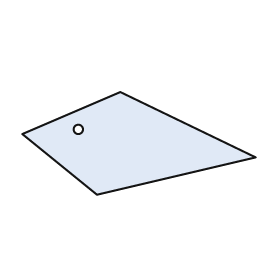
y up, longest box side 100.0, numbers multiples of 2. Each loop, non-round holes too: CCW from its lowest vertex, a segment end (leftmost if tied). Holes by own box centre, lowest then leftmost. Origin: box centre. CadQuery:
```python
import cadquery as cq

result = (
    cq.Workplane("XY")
    .moveTo(-18.0, -22.0)
    .lineTo(50.0, -6.0)
    .lineTo(-8.0, 22.0)
    .lineTo(-50.0, 4.0)
    .close()
    .moveTo(-26.0, 6.0)
    .circle(2.0)
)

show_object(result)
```